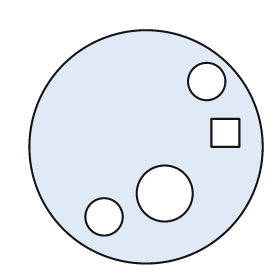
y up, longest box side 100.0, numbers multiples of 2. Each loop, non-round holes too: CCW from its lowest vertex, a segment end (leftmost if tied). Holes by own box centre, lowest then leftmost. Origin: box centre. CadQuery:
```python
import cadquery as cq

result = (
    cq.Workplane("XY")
    .moveTo(0.0, 0.0)
    .circle(50.0)
    .moveTo(-18.0, -30.0)
    .circle(8.0)
    .moveTo(8.0, -20.0)
    .circle(12.0)
    .moveTo(28.0, 0.0)
    .lineTo(40.0, 0.0)
    .lineTo(40.0, 12.0)
    .lineTo(28.0, 12.0)
    .close()
    .moveTo(26.0, 28.0)
    .circle(8.0)
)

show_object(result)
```